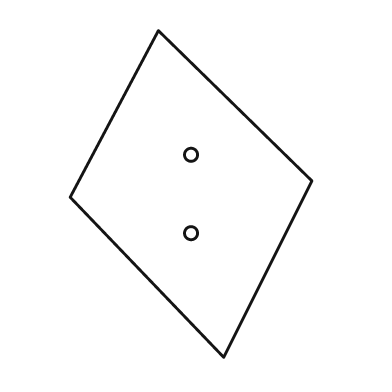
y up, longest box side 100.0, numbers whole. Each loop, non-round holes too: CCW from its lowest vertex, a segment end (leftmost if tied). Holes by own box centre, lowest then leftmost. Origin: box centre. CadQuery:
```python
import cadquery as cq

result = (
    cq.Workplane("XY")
    .moveTo(10.0, -50.0)
    .lineTo(37.0, 4.0)
    .lineTo(-10.0, 50.0)
    .lineTo(-37.0, -1.0)
    .close()
    .moveTo(0.0, -12.0)
    .circle(2.0)
    .moveTo(0.0, 12.0)
    .circle(2.0)
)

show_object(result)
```